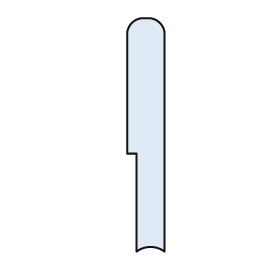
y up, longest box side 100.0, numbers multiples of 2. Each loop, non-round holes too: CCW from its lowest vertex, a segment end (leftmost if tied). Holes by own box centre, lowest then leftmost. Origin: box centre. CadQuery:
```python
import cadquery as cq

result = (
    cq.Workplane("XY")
    .moveTo(-4.0, -50.0)
    .threePointArc((2.0, -48.0), (8.0, -50.0))
    .lineTo(8.0, 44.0)
    .threePointArc((6.0, 48.0), (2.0, 50.0))
    .lineTo(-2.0, 50.0)
    .threePointArc((-6.0, 48.0), (-8.0, 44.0))
    .lineTo(-8.0, -8.0)
    .lineTo(-4.0, -8.0)
    .close()
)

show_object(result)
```